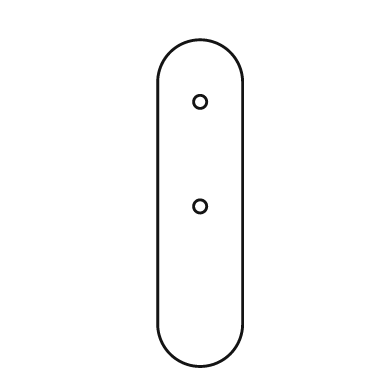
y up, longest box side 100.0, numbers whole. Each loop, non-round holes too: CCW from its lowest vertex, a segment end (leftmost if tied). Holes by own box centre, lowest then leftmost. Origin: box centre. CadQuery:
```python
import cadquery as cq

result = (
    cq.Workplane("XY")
    .moveTo(-13.0, -37.0)
    .threePointArc((0.0, -50.0), (13.0, -37.0))
    .lineTo(13.0, 37.0)
    .threePointArc((0.0, 50.0), (-13.0, 37.0))
    .close()
    .moveTo(0.0, -1.0)
    .circle(2.0)
    .moveTo(0.0, 31.0)
    .circle(2.0)
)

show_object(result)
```